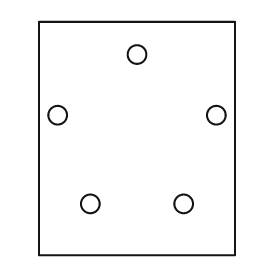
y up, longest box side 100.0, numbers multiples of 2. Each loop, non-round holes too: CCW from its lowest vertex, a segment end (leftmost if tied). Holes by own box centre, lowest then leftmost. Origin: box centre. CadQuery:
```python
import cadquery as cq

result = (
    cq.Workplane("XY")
    .moveTo(-42.0, -50.0)
    .lineTo(42.0, -50.0)
    .lineTo(42.0, 50.0)
    .lineTo(-42.0, 50.0)
    .close()
    .moveTo(-20.0, -28.0)
    .circle(4.0)
    .moveTo(20.0, -28.0)
    .circle(4.0)
    .moveTo(-34.0, 10.0)
    .circle(4.0)
    .moveTo(34.0, 10.0)
    .circle(4.0)
    .moveTo(0.0, 36.0)
    .circle(4.0)
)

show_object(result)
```